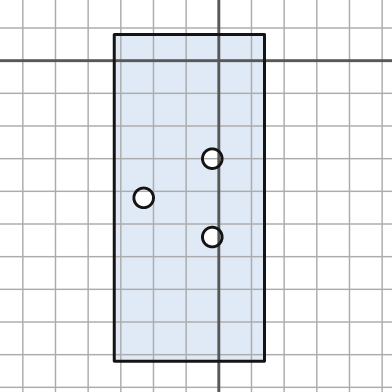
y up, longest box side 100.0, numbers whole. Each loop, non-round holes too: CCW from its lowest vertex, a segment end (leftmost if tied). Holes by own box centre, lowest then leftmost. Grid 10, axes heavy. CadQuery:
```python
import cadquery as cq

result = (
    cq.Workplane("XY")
    .moveTo(-32.0, -92.0)
    .lineTo(14.0, -92.0)
    .lineTo(14.0, 8.0)
    .lineTo(-32.0, 8.0)
    .close()
    .moveTo(-2.0, -54.0)
    .circle(3.0)
    .moveTo(-23.0, -42.0)
    .circle(3.0)
    .moveTo(-2.0, -30.0)
    .circle(3.0)
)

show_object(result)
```